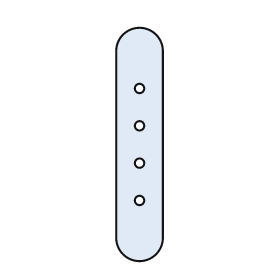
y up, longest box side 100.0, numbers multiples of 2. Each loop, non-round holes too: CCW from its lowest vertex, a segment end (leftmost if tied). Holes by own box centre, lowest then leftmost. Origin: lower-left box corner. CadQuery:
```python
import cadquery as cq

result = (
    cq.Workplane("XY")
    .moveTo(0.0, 10.0)
    .threePointArc((10.0, 0.0), (20.0, 10.0))
    .lineTo(20.0, 90.0)
    .threePointArc((10.0, 100.0), (0.0, 90.0))
    .close()
    .moveTo(10.0, 26.0)
    .circle(2.0)
    .moveTo(10.0, 42.0)
    .circle(2.0)
    .moveTo(10.0, 58.0)
    .circle(2.0)
    .moveTo(10.0, 74.0)
    .circle(2.0)
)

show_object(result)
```